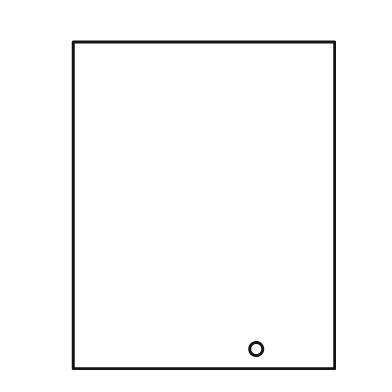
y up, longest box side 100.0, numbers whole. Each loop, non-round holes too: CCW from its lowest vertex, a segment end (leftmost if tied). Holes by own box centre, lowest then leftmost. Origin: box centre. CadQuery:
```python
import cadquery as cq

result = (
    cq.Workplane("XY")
    .moveTo(-40.0, -50.0)
    .lineTo(40.0, -50.0)
    .lineTo(40.0, 50.0)
    .lineTo(-40.0, 50.0)
    .close()
    .moveTo(16.0, -44.0)
    .circle(2.0)
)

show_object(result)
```